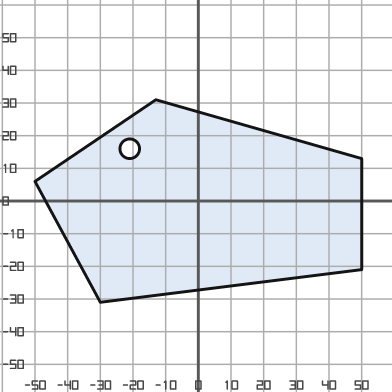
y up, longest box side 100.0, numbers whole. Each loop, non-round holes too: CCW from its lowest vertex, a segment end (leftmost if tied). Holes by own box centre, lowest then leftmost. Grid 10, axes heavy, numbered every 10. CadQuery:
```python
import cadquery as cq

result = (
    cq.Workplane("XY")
    .moveTo(-30.0, -31.0)
    .lineTo(50.0, -21.0)
    .lineTo(50.0, 13.0)
    .lineTo(-13.0, 31.0)
    .lineTo(-50.0, 6.0)
    .close()
    .moveTo(-21.0, 16.0)
    .circle(3.0)
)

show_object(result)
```